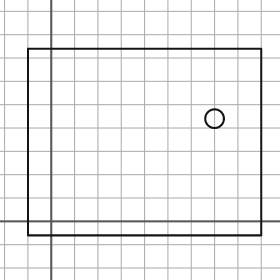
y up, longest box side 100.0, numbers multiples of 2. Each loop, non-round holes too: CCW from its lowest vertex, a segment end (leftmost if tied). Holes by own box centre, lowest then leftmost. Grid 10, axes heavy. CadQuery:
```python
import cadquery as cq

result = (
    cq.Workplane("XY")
    .moveTo(-10.0, -6.0)
    .lineTo(90.0, -6.0)
    .lineTo(90.0, 74.0)
    .lineTo(-10.0, 74.0)
    .close()
    .moveTo(70.0, 44.0)
    .circle(4.0)
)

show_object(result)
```